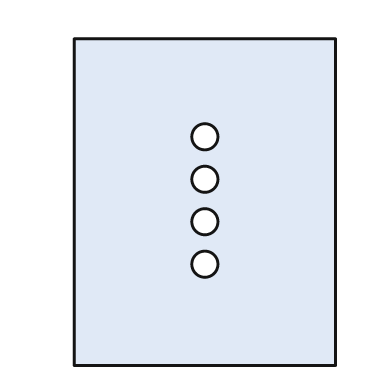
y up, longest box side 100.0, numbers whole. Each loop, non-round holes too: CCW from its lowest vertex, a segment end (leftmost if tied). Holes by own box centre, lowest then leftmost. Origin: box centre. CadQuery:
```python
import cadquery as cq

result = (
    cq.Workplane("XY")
    .moveTo(-40.0, -50.0)
    .lineTo(40.0, -50.0)
    .lineTo(40.0, 50.0)
    .lineTo(-40.0, 50.0)
    .close()
    .moveTo(0.0, -19.0)
    .circle(4.0)
    .moveTo(0.0, -6.0)
    .circle(4.0)
    .moveTo(0.0, 7.0)
    .circle(4.0)
    .moveTo(0.0, 20.0)
    .circle(4.0)
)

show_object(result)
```